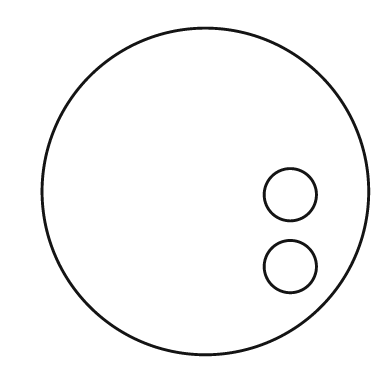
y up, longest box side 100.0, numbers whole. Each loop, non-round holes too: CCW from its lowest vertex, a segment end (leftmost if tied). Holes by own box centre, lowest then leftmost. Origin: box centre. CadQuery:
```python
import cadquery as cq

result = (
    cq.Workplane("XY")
    .moveTo(0.0, 0.0)
    .circle(50.0)
    .moveTo(26.0, -23.0)
    .circle(8.0)
    .moveTo(26.0, -1.0)
    .circle(8.0)
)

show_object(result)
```